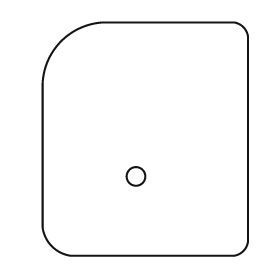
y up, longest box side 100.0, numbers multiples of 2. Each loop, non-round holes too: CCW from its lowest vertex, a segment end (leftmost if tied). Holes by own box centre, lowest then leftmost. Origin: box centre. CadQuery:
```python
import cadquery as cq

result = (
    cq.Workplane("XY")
    .moveTo(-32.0, -50.0)
    .lineTo(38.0, -50.0)
    .threePointArc((42.0, -48.0), (44.0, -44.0))
    .lineTo(44.0, 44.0)
    .threePointArc((42.0, 48.0), (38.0, 50.0))
    .lineTo(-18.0, 50.0)
    .threePointArc((-36.0, 42.0), (-44.0, 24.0))
    .lineTo(-44.0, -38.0)
    .threePointArc((-40.0, -46.0), (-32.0, -50.0))
    .close()
    .moveTo(-4.0, -16.0)
    .circle(4.0)
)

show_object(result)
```